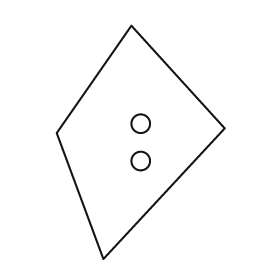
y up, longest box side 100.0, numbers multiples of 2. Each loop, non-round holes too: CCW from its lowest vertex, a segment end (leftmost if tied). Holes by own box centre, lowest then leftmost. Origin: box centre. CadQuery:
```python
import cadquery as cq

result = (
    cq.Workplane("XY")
    .moveTo(-16.0, -50.0)
    .lineTo(36.0, 6.0)
    .lineTo(-4.0, 50.0)
    .lineTo(-36.0, 4.0)
    .close()
    .moveTo(0.0, -8.0)
    .circle(4.0)
    .moveTo(0.0, 8.0)
    .circle(4.0)
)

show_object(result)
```